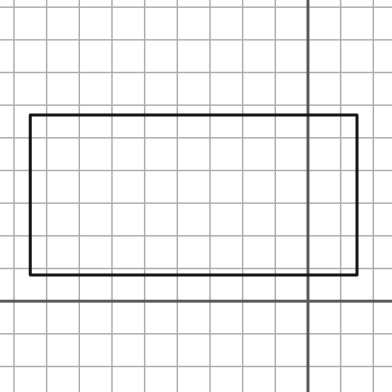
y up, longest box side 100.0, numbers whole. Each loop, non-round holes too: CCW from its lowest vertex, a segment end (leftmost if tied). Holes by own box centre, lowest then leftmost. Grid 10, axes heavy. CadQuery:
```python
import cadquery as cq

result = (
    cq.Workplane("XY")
    .moveTo(-85.0, 8.0)
    .lineTo(15.0, 8.0)
    .lineTo(15.0, 57.0)
    .lineTo(-85.0, 57.0)
    .close()
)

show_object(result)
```